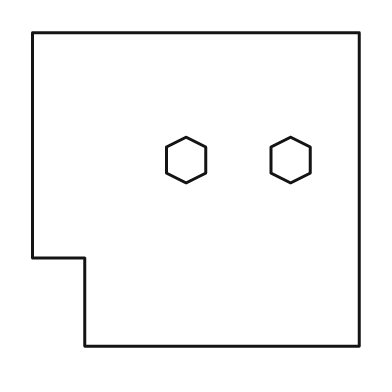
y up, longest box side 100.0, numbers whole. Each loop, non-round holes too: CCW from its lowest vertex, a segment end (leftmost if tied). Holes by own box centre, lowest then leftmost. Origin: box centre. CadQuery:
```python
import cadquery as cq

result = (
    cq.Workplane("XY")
    .moveTo(-34.0, -48.0)
    .lineTo(50.0, -48.0)
    .lineTo(50.0, 48.0)
    .lineTo(-50.0, 48.0)
    .lineTo(-50.0, -21.0)
    .lineTo(-34.0, -21.0)
    .close()
    .moveTo(-3.0, 2.0)
    .lineTo(3.0, 5.0)
    .lineTo(3.0, 13.0)
    .lineTo(-3.0, 16.0)
    .lineTo(-9.0, 13.0)
    .lineTo(-9.0, 5.0)
    .close()
    .moveTo(29.0, 2.0)
    .lineTo(35.0, 5.0)
    .lineTo(35.0, 13.0)
    .lineTo(29.0, 16.0)
    .lineTo(23.0, 13.0)
    .lineTo(23.0, 5.0)
    .close()
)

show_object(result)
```